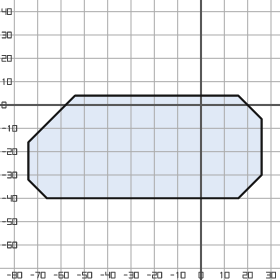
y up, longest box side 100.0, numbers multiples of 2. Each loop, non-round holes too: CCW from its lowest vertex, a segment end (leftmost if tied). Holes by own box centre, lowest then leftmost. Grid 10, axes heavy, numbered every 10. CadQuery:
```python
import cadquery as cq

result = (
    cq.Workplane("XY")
    .moveTo(-66.0, -40.0)
    .lineTo(16.0, -40.0)
    .lineTo(26.0, -30.0)
    .lineTo(26.0, -6.0)
    .lineTo(16.0, 4.0)
    .lineTo(-54.0, 4.0)
    .lineTo(-74.0, -16.0)
    .lineTo(-74.0, -32.0)
    .close()
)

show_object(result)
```